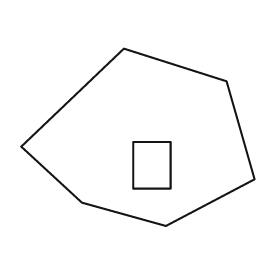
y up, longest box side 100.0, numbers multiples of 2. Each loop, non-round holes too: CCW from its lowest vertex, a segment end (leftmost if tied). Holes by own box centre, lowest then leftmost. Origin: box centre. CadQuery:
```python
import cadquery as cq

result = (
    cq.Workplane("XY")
    .moveTo(12.0, -38.0)
    .lineTo(50.0, -18.0)
    .lineTo(38.0, 24.0)
    .lineTo(-6.0, 38.0)
    .lineTo(-50.0, -4.0)
    .lineTo(-24.0, -28.0)
    .close()
    .moveTo(-2.0, -22.0)
    .lineTo(14.0, -22.0)
    .lineTo(14.0, -2.0)
    .lineTo(-2.0, -2.0)
    .close()
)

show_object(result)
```